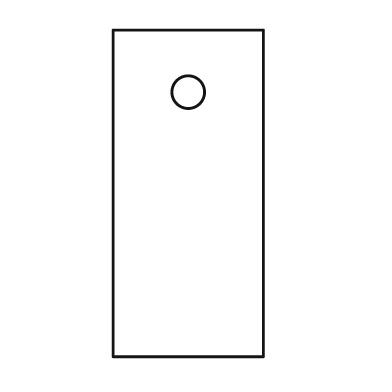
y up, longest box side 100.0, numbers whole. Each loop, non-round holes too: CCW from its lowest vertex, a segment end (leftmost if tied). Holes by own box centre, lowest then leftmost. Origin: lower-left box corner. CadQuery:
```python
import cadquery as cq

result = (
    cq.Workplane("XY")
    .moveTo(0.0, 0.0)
    .lineTo(46.0, 0.0)
    .lineTo(46.0, 100.0)
    .lineTo(0.0, 100.0)
    .close()
    .moveTo(23.0, 81.0)
    .circle(5.0)
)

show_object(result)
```